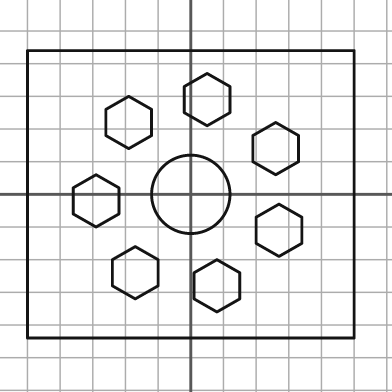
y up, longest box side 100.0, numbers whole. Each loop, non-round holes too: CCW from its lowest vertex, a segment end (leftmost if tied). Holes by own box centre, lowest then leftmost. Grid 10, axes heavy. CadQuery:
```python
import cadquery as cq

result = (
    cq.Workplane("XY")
    .moveTo(-50.0, -44.0)
    .lineTo(50.0, -44.0)
    .lineTo(50.0, 44.0)
    .lineTo(-50.0, 44.0)
    .close()
    .moveTo(8.0, -36.0)
    .lineTo(15.0, -32.0)
    .lineTo(15.0, -24.0)
    .lineTo(8.0, -20.0)
    .lineTo(1.0, -24.0)
    .lineTo(1.0, -32.0)
    .close()
    .moveTo(-17.0, -32.0)
    .lineTo(-10.0, -28.0)
    .lineTo(-10.0, -20.0)
    .lineTo(-17.0, -16.0)
    .lineTo(-24.0, -20.0)
    .lineTo(-24.0, -28.0)
    .close()
    .moveTo(27.0, -19.0)
    .lineTo(34.0, -15.0)
    .lineTo(34.0, -7.0)
    .lineTo(27.0, -3.0)
    .lineTo(20.0, -7.0)
    .lineTo(20.0, -15.0)
    .close()
    .moveTo(-29.0, -10.0)
    .lineTo(-22.0, -6.0)
    .lineTo(-22.0, 2.0)
    .lineTo(-29.0, 6.0)
    .lineTo(-36.0, 2.0)
    .lineTo(-36.0, -6.0)
    .close()
    .moveTo(0.0, 0.0)
    .circle(12.0)
    .moveTo(26.0, 6.0)
    .lineTo(33.0, 10.0)
    .lineTo(33.0, 18.0)
    .lineTo(26.0, 22.0)
    .lineTo(19.0, 18.0)
    .lineTo(19.0, 10.0)
    .close()
    .moveTo(-19.0, 14.0)
    .lineTo(-12.0, 18.0)
    .lineTo(-12.0, 26.0)
    .lineTo(-19.0, 30.0)
    .lineTo(-26.0, 26.0)
    .lineTo(-26.0, 18.0)
    .close()
    .moveTo(5.0, 21.0)
    .lineTo(12.0, 25.0)
    .lineTo(12.0, 33.0)
    .lineTo(5.0, 37.0)
    .lineTo(-2.0, 33.0)
    .lineTo(-2.0, 25.0)
    .close()
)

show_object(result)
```